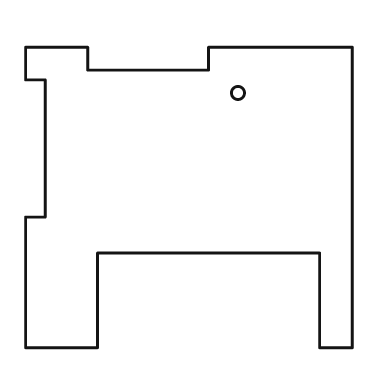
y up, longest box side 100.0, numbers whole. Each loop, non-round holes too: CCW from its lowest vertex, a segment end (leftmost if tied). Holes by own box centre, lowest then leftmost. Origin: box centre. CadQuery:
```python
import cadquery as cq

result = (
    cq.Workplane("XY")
    .moveTo(-50.0, -46.0)
    .lineTo(-28.0, -46.0)
    .lineTo(-28.0, -17.0)
    .lineTo(40.0, -17.0)
    .lineTo(40.0, -46.0)
    .lineTo(50.0, -46.0)
    .lineTo(50.0, 46.0)
    .lineTo(6.0, 46.0)
    .lineTo(6.0, 39.0)
    .lineTo(-31.0, 39.0)
    .lineTo(-31.0, 46.0)
    .lineTo(-50.0, 46.0)
    .lineTo(-50.0, 36.0)
    .lineTo(-44.0, 36.0)
    .lineTo(-44.0, -6.0)
    .lineTo(-50.0, -6.0)
    .close()
    .moveTo(15.0, 32.0)
    .circle(2.0)
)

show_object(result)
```